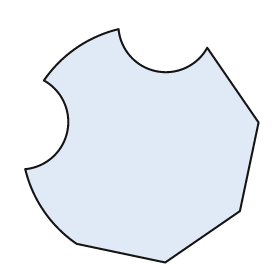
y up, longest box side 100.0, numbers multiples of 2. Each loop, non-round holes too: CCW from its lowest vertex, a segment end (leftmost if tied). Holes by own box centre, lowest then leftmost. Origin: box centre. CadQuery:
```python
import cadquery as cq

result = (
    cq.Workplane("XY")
    .moveTo(10.0, -50.0)
    .lineTo(42.0, -28.0)
    .lineTo(50.0, 10.0)
    .lineTo(28.0, 42.0)
    .threePointArc((6.0, 32.0), (-10.0, 50.0))
    .threePointArc((-28.0, 42.0), (-42.0, 28.0))
    .threePointArc((-32.0, 6.0), (-50.0, -10.0))
    .threePointArc((-42.0, -28.0), (-28.0, -42.0))
    .close()
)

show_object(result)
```